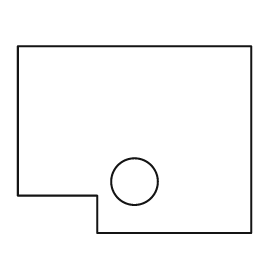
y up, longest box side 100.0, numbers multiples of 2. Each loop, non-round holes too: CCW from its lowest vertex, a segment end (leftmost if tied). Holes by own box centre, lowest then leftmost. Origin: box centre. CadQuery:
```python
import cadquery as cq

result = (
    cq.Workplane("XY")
    .moveTo(-16.0, -40.0)
    .lineTo(50.0, -40.0)
    .lineTo(50.0, 40.0)
    .lineTo(-50.0, 40.0)
    .lineTo(-50.0, -24.0)
    .lineTo(-16.0, -24.0)
    .close()
    .moveTo(0.0, -18.0)
    .circle(10.0)
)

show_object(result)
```